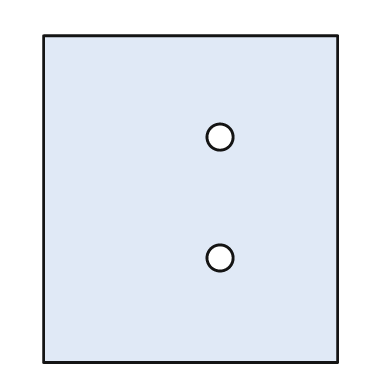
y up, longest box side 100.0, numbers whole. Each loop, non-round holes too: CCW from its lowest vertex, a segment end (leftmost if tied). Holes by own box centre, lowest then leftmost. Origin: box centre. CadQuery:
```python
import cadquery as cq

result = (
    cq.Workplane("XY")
    .moveTo(-45.0, -50.0)
    .lineTo(45.0, -50.0)
    .lineTo(45.0, 50.0)
    .lineTo(-45.0, 50.0)
    .close()
    .moveTo(9.0, -18.0)
    .circle(4.0)
    .moveTo(9.0, 19.0)
    .circle(4.0)
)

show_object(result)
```